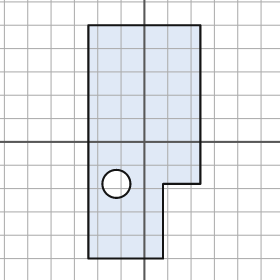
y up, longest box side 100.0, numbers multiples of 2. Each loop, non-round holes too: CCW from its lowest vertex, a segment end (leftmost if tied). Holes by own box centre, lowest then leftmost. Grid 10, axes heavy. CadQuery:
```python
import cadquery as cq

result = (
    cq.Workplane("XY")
    .moveTo(-24.0, -50.0)
    .lineTo(8.0, -50.0)
    .lineTo(8.0, -18.0)
    .lineTo(24.0, -18.0)
    .lineTo(24.0, 50.0)
    .lineTo(-24.0, 50.0)
    .close()
    .moveTo(-12.0, -18.0)
    .circle(6.0)
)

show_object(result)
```